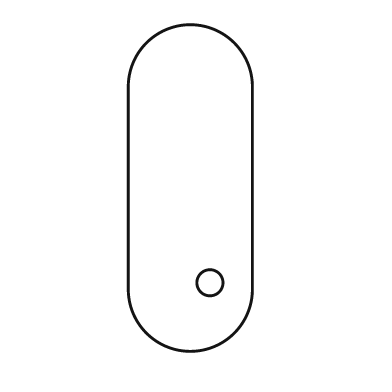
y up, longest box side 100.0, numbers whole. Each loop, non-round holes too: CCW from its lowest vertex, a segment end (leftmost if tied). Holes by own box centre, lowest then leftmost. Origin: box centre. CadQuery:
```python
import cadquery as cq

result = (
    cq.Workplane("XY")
    .moveTo(-19.0, -31.0)
    .threePointArc((0.0, -50.0), (19.0, -31.0))
    .lineTo(19.0, 31.0)
    .threePointArc((0.0, 50.0), (-19.0, 31.0))
    .close()
    .moveTo(6.0, -29.0)
    .circle(4.0)
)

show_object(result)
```